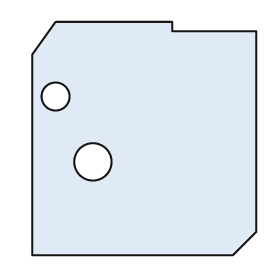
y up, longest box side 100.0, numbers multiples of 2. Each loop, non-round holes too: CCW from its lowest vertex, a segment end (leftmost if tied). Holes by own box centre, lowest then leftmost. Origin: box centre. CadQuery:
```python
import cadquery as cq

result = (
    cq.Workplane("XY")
    .moveTo(-48.0, -50.0)
    .lineTo(38.0, -50.0)
    .lineTo(48.0, -40.0)
    .lineTo(48.0, 46.0)
    .lineTo(12.0, 46.0)
    .lineTo(12.0, 50.0)
    .lineTo(-38.0, 50.0)
    .lineTo(-48.0, 36.0)
    .close()
    .moveTo(-22.0, -10.0)
    .circle(8.0)
    .moveTo(-38.0, 18.0)
    .circle(6.0)
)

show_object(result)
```